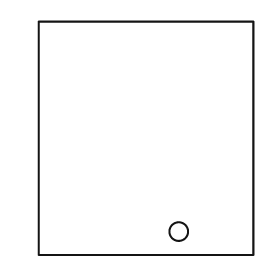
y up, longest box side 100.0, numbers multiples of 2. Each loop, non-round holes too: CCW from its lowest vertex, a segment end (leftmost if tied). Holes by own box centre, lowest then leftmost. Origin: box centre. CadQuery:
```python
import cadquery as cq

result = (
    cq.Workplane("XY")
    .moveTo(-46.0, -50.0)
    .lineTo(46.0, -50.0)
    .lineTo(46.0, 50.0)
    .lineTo(-46.0, 50.0)
    .close()
    .moveTo(14.0, -40.0)
    .circle(4.0)
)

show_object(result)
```